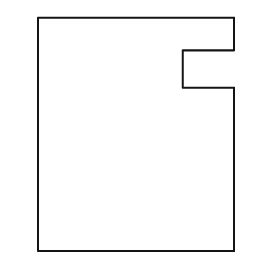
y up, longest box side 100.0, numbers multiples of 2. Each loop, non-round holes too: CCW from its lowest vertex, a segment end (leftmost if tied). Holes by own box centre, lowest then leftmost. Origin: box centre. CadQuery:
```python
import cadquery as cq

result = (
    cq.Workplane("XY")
    .moveTo(-42.0, -50.0)
    .lineTo(42.0, -50.0)
    .lineTo(42.0, 20.0)
    .lineTo(20.0, 20.0)
    .lineTo(20.0, 36.0)
    .lineTo(42.0, 36.0)
    .lineTo(42.0, 50.0)
    .lineTo(-42.0, 50.0)
    .close()
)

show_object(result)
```